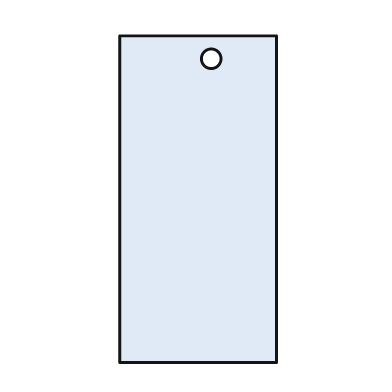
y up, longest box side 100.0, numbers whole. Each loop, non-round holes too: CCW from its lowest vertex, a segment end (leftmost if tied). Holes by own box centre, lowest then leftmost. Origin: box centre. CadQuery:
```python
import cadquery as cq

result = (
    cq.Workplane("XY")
    .moveTo(-24.0, -50.0)
    .lineTo(24.0, -50.0)
    .lineTo(24.0, 50.0)
    .lineTo(-24.0, 50.0)
    .close()
    .moveTo(4.0, 43.0)
    .circle(3.0)
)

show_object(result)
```